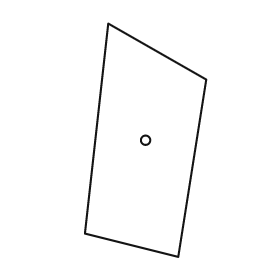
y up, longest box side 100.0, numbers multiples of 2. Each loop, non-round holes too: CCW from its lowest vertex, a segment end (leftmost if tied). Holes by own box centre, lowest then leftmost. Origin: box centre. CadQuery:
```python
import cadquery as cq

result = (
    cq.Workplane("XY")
    .moveTo(14.0, -50.0)
    .lineTo(26.0, 26.0)
    .lineTo(-16.0, 50.0)
    .lineTo(-26.0, -40.0)
    .close()
    .moveTo(0.0, 0.0)
    .circle(2.0)
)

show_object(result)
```